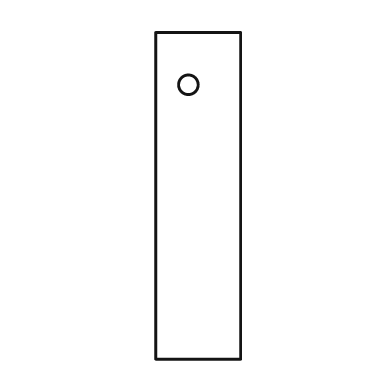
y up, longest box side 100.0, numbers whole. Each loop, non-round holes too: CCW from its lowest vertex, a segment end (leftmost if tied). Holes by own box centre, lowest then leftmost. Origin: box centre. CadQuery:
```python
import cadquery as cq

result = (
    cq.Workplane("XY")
    .moveTo(-13.0, -50.0)
    .lineTo(13.0, -50.0)
    .lineTo(13.0, 50.0)
    .lineTo(-13.0, 50.0)
    .close()
    .moveTo(-3.0, 34.0)
    .circle(3.0)
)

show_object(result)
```